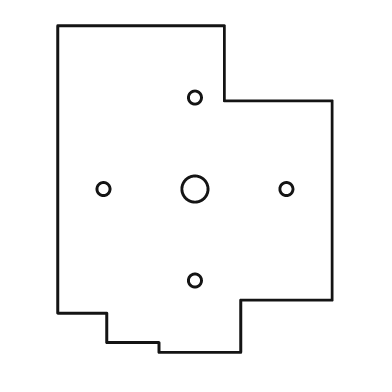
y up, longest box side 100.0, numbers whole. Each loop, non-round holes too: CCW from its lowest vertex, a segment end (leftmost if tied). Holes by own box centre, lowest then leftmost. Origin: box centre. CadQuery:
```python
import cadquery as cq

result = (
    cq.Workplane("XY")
    .moveTo(-11.0, -50.0)
    .lineTo(14.0, -50.0)
    .lineTo(14.0, -34.0)
    .lineTo(42.0, -34.0)
    .lineTo(42.0, 27.0)
    .lineTo(9.0, 27.0)
    .lineTo(9.0, 50.0)
    .lineTo(-42.0, 50.0)
    .lineTo(-42.0, -38.0)
    .lineTo(-27.0, -38.0)
    .lineTo(-27.0, -47.0)
    .lineTo(-11.0, -47.0)
    .close()
    .moveTo(0.0, -28.0)
    .circle(2.0)
    .moveTo(-28.0, 0.0)
    .circle(2.0)
    .moveTo(0.0, 0.0)
    .circle(4.0)
    .moveTo(28.0, 0.0)
    .circle(2.0)
    .moveTo(0.0, 28.0)
    .circle(2.0)
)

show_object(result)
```